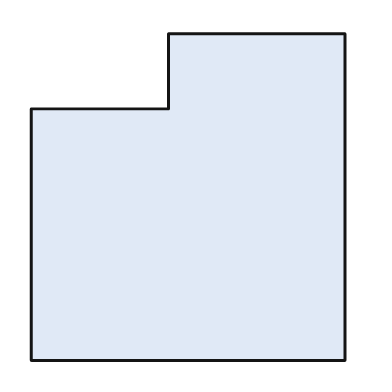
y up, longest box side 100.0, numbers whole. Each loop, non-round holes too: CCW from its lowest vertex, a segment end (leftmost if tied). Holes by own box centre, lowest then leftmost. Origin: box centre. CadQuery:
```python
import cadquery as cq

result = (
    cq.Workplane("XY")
    .moveTo(-48.0, -50.0)
    .lineTo(48.0, -50.0)
    .lineTo(48.0, 50.0)
    .lineTo(-6.0, 50.0)
    .lineTo(-6.0, 27.0)
    .lineTo(-48.0, 27.0)
    .close()
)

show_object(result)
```